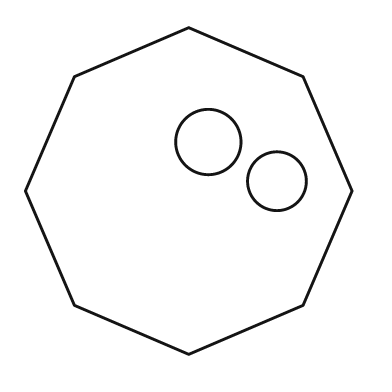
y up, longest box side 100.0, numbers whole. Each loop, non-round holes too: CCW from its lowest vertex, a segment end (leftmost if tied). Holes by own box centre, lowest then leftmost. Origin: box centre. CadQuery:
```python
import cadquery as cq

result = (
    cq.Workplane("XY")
    .moveTo(0.0, -50.0)
    .lineTo(35.0, -35.0)
    .lineTo(50.0, 0.0)
    .lineTo(35.0, 35.0)
    .lineTo(0.0, 50.0)
    .lineTo(-35.0, 35.0)
    .lineTo(-50.0, 0.0)
    .lineTo(-35.0, -35.0)
    .close()
    .moveTo(27.0, 3.0)
    .circle(9.0)
    .moveTo(6.0, 15.0)
    .circle(10.0)
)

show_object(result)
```